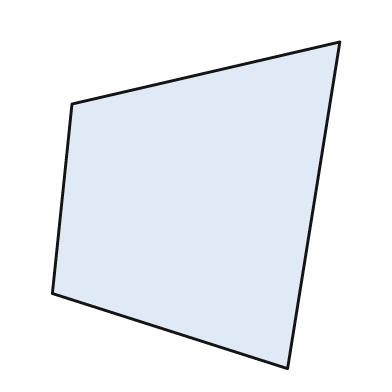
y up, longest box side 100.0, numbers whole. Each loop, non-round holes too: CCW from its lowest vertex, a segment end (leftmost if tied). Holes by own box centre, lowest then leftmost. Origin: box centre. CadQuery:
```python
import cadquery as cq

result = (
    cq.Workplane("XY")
    .moveTo(28.0, -50.0)
    .lineTo(44.0, 50.0)
    .lineTo(-38.0, 31.0)
    .lineTo(-44.0, -27.0)
    .close()
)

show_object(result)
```